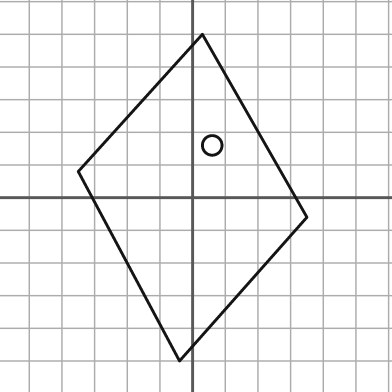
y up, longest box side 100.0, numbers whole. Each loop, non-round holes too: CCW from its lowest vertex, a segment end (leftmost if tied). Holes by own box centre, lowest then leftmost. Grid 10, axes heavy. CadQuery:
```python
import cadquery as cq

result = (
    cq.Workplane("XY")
    .moveTo(-4.0, -50.0)
    .lineTo(35.0, -6.0)
    .lineTo(3.0, 50.0)
    .lineTo(-35.0, 8.0)
    .close()
    .moveTo(6.0, 16.0)
    .circle(3.0)
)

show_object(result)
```